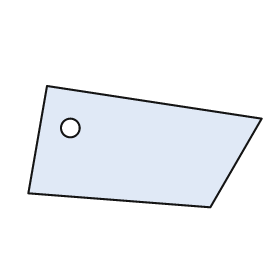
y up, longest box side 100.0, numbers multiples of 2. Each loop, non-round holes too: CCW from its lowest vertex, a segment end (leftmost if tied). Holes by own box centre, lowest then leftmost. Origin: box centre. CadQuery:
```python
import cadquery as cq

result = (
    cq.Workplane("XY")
    .moveTo(28.0, -26.0)
    .lineTo(50.0, 12.0)
    .lineTo(-42.0, 26.0)
    .lineTo(-50.0, -20.0)
    .close()
    .moveTo(-32.0, 8.0)
    .circle(4.0)
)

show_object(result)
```